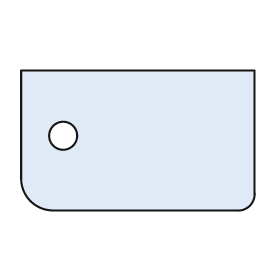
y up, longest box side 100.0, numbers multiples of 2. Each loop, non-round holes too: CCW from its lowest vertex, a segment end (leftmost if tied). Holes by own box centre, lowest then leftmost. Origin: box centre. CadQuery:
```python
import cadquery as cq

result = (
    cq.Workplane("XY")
    .moveTo(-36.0, -30.0)
    .lineTo(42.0, -30.0)
    .threePointArc((48.0, -28.0), (50.0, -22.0))
    .lineTo(50.0, 30.0)
    .lineTo(-50.0, 30.0)
    .lineTo(-50.0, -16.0)
    .threePointArc((-46.0, -26.0), (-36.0, -30.0))
    .close()
    .moveTo(-32.0, 2.0)
    .circle(6.0)
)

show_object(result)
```